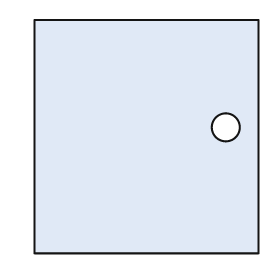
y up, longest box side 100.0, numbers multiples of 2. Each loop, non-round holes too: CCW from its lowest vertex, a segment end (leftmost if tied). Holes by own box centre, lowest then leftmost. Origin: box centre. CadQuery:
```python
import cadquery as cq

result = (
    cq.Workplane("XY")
    .moveTo(-48.0, -50.0)
    .lineTo(48.0, -50.0)
    .lineTo(48.0, 50.0)
    .lineTo(-48.0, 50.0)
    .close()
    .moveTo(34.0, 4.0)
    .circle(6.0)
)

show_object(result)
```